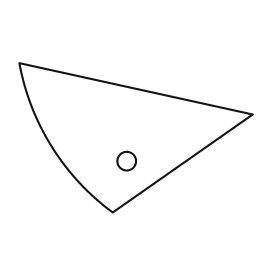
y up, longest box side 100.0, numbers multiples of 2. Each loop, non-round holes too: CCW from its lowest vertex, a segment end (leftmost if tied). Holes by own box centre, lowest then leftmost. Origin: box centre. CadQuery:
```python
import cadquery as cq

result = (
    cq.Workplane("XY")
    .moveTo(-10.0, -32.0)
    .lineTo(50.0, 10.0)
    .lineTo(-50.0, 32.0)
    .threePointArc((-36.0, -4.0), (-10.0, -32.0))
    .close()
    .moveTo(-4.0, -10.0)
    .circle(4.0)
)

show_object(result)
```